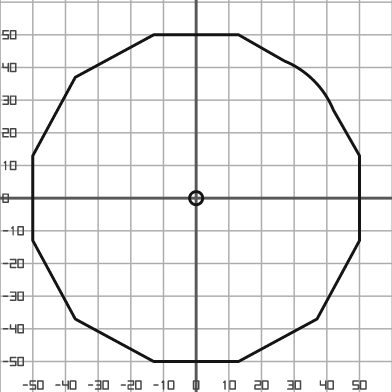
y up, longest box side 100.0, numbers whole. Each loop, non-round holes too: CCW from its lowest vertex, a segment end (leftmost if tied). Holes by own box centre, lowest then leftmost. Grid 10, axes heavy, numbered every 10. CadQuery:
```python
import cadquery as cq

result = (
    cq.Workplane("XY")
    .moveTo(-13.0, -50.0)
    .lineTo(13.0, -50.0)
    .lineTo(37.0, -37.0)
    .lineTo(50.0, -13.0)
    .lineTo(50.0, 13.0)
    .lineTo(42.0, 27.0)
    .threePointArc((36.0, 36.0), (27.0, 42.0))
    .lineTo(13.0, 50.0)
    .lineTo(-13.0, 50.0)
    .lineTo(-37.0, 37.0)
    .lineTo(-50.0, 13.0)
    .lineTo(-50.0, -13.0)
    .lineTo(-37.0, -37.0)
    .close()
    .moveTo(0.0, 0.0)
    .circle(2.0)
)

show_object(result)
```